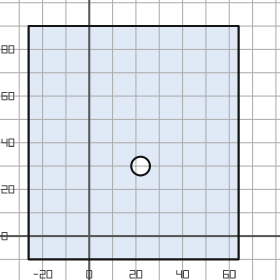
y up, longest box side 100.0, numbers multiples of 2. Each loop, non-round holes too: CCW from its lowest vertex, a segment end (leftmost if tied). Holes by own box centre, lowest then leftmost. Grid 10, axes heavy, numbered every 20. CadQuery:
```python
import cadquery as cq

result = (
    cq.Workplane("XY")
    .moveTo(-26.0, -10.0)
    .lineTo(64.0, -10.0)
    .lineTo(64.0, 90.0)
    .lineTo(-26.0, 90.0)
    .close()
    .moveTo(22.0, 30.0)
    .circle(4.0)
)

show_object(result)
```